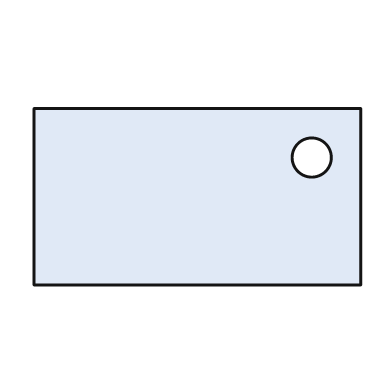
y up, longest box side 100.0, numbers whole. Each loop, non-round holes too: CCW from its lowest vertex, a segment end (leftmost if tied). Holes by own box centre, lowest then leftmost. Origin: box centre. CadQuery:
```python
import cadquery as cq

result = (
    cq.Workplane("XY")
    .moveTo(-50.0, -27.0)
    .lineTo(50.0, -27.0)
    .lineTo(50.0, 27.0)
    .lineTo(-50.0, 27.0)
    .close()
    .moveTo(35.0, 12.0)
    .circle(6.0)
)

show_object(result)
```